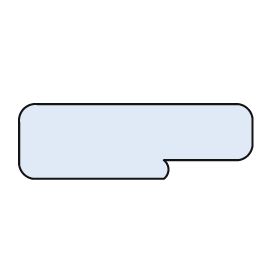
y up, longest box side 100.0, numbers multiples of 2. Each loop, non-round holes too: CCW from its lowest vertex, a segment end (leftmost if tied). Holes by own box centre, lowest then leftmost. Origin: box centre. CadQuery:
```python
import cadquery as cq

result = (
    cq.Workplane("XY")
    .moveTo(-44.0, -16.0)
    .lineTo(12.0, -16.0)
    .threePointArc((14.0, -12.0), (12.0, -8.0))
    .lineTo(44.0, -8.0)
    .threePointArc((48.0, -6.0), (50.0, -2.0))
    .lineTo(50.0, 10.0)
    .threePointArc((48.0, 14.0), (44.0, 16.0))
    .lineTo(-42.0, 16.0)
    .threePointArc((-48.0, 14.0), (-50.0, 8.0))
    .lineTo(-50.0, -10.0)
    .threePointArc((-48.0, -14.0), (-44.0, -16.0))
    .close()
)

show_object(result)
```